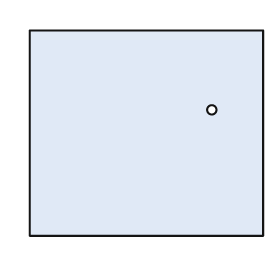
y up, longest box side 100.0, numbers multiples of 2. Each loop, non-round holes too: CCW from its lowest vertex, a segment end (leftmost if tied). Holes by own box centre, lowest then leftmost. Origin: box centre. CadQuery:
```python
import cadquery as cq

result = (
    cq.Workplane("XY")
    .moveTo(-50.0, -44.0)
    .lineTo(50.0, -44.0)
    .lineTo(50.0, 44.0)
    .lineTo(-50.0, 44.0)
    .close()
    .moveTo(28.0, 10.0)
    .circle(2.0)
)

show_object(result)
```